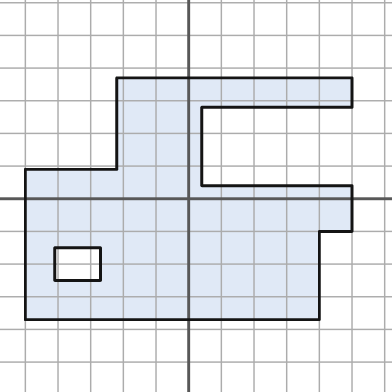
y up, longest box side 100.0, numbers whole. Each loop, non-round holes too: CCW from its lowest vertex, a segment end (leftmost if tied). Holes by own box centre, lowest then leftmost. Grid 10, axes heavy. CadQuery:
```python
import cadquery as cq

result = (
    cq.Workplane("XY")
    .moveTo(-50.0, -37.0)
    .lineTo(40.0, -37.0)
    .lineTo(40.0, -10.0)
    .lineTo(50.0, -10.0)
    .lineTo(50.0, 4.0)
    .lineTo(4.0, 4.0)
    .lineTo(4.0, 28.0)
    .lineTo(50.0, 28.0)
    .lineTo(50.0, 37.0)
    .lineTo(-22.0, 37.0)
    .lineTo(-22.0, 9.0)
    .lineTo(-50.0, 9.0)
    .close()
    .moveTo(-41.0, -25.0)
    .lineTo(-27.0, -25.0)
    .lineTo(-27.0, -15.0)
    .lineTo(-41.0, -15.0)
    .close()
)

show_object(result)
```